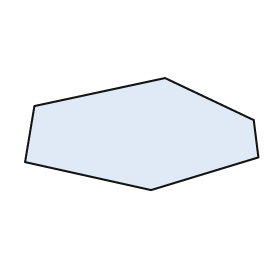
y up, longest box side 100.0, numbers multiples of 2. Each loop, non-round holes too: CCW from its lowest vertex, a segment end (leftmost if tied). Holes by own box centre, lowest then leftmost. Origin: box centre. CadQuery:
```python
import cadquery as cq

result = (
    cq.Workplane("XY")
    .moveTo(4.0, -24.0)
    .lineTo(50.0, -10.0)
    .lineTo(48.0, 6.0)
    .lineTo(10.0, 24.0)
    .lineTo(-46.0, 12.0)
    .lineTo(-50.0, -12.0)
    .close()
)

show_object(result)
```